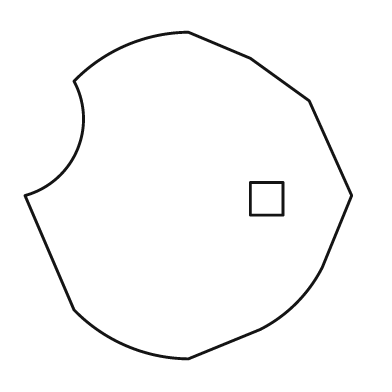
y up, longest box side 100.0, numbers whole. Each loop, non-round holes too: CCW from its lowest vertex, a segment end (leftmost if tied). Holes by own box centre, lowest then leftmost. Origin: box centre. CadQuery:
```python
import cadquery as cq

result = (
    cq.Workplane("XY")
    .moveTo(0.0, -50.0)
    .lineTo(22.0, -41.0)
    .threePointArc((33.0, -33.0), (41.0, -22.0))
    .lineTo(50.0, 0.0)
    .lineTo(37.0, 29.0)
    .lineTo(19.0, 42.0)
    .lineTo(0.0, 50.0)
    .threePointArc((-19.0, 46.0), (-35.0, 35.0))
    .threePointArc((-34.0, 14.0), (-50.0, 0.0))
    .lineTo(-35.0, -35.0)
    .threePointArc((-19.0, -46.0), (0.0, -50.0))
    .close()
    .moveTo(19.0, -6.0)
    .lineTo(29.0, -6.0)
    .lineTo(29.0, 4.0)
    .lineTo(19.0, 4.0)
    .close()
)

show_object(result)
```